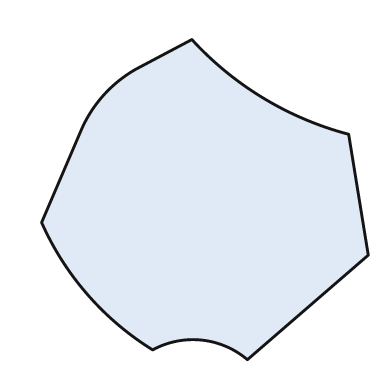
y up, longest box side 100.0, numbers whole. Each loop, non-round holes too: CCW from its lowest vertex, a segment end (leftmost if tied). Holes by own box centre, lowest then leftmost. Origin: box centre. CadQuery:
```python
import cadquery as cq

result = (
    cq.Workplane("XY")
    .moveTo(13.0, -49.0)
    .lineTo(50.0, -17.0)
    .lineTo(44.0, 20.0)
    .threePointArc((18.0, 31.0), (-4.0, 49.0))
    .lineTo(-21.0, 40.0)
    .threePointArc((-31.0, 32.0), (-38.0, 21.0))
    .lineTo(-50.0, -7.0)
    .threePointArc((-36.0, -29.0), (-16.0, -46.0))
    .threePointArc((-1.0, -43.0), (13.0, -49.0))
    .close()
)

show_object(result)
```